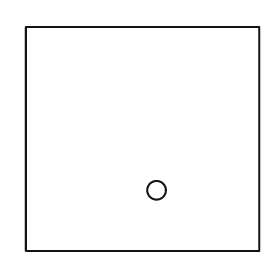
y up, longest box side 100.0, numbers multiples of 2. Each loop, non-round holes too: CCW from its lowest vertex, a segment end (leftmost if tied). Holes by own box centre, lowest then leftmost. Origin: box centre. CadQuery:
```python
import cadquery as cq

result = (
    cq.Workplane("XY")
    .moveTo(-50.0, -48.0)
    .lineTo(50.0, -48.0)
    .lineTo(50.0, 48.0)
    .lineTo(-50.0, 48.0)
    .close()
    .moveTo(6.0, -22.0)
    .circle(4.0)
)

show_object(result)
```